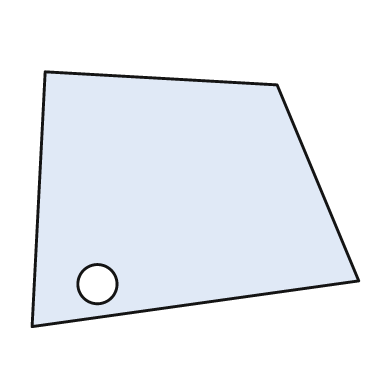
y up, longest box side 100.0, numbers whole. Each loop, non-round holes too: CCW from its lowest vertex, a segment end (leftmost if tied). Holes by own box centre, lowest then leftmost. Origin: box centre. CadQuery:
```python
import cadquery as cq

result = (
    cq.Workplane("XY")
    .moveTo(-50.0, -39.0)
    .lineTo(50.0, -25.0)
    .lineTo(25.0, 35.0)
    .lineTo(-46.0, 39.0)
    .close()
    .moveTo(-30.0, -26.0)
    .circle(6.0)
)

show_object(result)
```